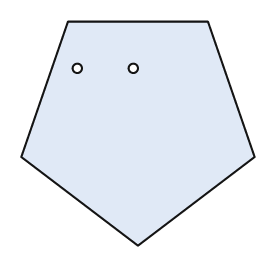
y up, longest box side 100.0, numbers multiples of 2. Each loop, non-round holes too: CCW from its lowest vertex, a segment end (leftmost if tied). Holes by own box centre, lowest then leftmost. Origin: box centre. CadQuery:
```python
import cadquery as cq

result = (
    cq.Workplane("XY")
    .moveTo(0.0, -48.0)
    .lineTo(50.0, -10.0)
    .lineTo(30.0, 48.0)
    .lineTo(-30.0, 48.0)
    .lineTo(-50.0, -10.0)
    .close()
    .moveTo(-26.0, 28.0)
    .circle(2.0)
    .moveTo(-2.0, 28.0)
    .circle(2.0)
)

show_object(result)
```